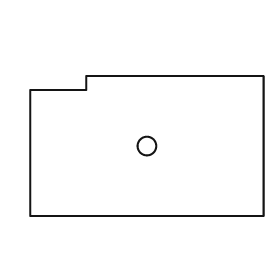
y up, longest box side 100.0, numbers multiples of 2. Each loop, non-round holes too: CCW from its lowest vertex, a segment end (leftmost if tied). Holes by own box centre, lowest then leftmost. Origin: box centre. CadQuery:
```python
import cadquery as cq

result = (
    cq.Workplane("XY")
    .moveTo(-50.0, -30.0)
    .lineTo(50.0, -30.0)
    .lineTo(50.0, 30.0)
    .lineTo(-26.0, 30.0)
    .lineTo(-26.0, 24.0)
    .lineTo(-50.0, 24.0)
    .close()
    .moveTo(0.0, 0.0)
    .circle(4.0)
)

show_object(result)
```